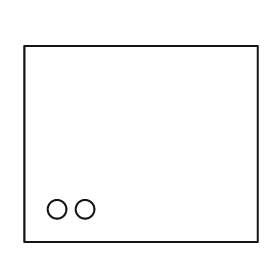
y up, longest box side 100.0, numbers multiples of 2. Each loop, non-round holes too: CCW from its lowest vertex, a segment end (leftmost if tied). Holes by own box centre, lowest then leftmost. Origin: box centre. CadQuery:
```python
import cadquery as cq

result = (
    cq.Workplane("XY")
    .moveTo(-50.0, -42.0)
    .lineTo(50.0, -42.0)
    .lineTo(50.0, 42.0)
    .lineTo(-50.0, 42.0)
    .close()
    .moveTo(-36.0, -28.0)
    .circle(4.0)
    .moveTo(-24.0, -28.0)
    .circle(4.0)
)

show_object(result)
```